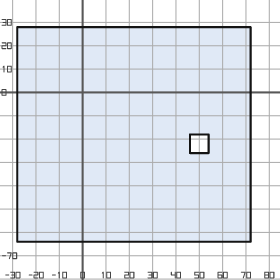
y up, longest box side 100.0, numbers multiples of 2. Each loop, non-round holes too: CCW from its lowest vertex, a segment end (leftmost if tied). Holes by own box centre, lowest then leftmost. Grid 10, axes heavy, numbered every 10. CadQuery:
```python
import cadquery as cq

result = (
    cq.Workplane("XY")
    .moveTo(-28.0, -64.0)
    .lineTo(72.0, -64.0)
    .lineTo(72.0, 28.0)
    .lineTo(-28.0, 28.0)
    .close()
    .moveTo(46.0, -26.0)
    .lineTo(54.0, -26.0)
    .lineTo(54.0, -18.0)
    .lineTo(46.0, -18.0)
    .close()
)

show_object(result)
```